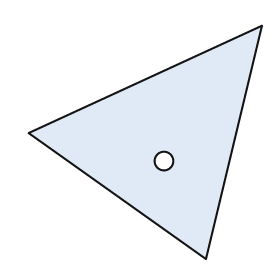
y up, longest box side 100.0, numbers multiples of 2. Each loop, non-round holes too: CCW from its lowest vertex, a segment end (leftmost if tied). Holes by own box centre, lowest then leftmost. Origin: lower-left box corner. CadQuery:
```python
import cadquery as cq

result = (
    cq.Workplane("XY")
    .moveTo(76.0, 0.0)
    .lineTo(100.0, 100.0)
    .lineTo(0.0, 54.0)
    .close()
    .moveTo(58.0, 42.0)
    .circle(4.0)
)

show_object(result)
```